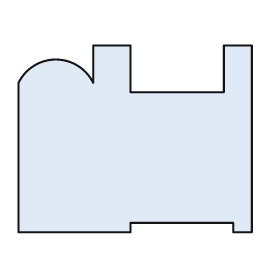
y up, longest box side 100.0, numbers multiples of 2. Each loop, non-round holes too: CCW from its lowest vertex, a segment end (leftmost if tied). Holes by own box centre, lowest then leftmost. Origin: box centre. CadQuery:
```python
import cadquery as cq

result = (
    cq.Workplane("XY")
    .moveTo(-50.0, -40.0)
    .lineTo(-2.0, -40.0)
    .lineTo(-2.0, -36.0)
    .lineTo(42.0, -36.0)
    .lineTo(42.0, -40.0)
    .lineTo(50.0, -40.0)
    .lineTo(50.0, 40.0)
    .lineTo(38.0, 40.0)
    .lineTo(38.0, 20.0)
    .lineTo(-2.0, 20.0)
    .lineTo(-2.0, 40.0)
    .lineTo(-18.0, 40.0)
    .lineTo(-18.0, 24.0)
    .threePointArc((-34.0, 34.0), (-50.0, 24.0))
    .close()
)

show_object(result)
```